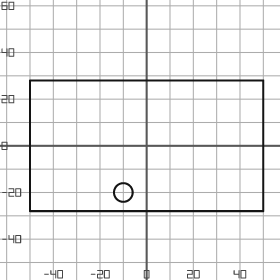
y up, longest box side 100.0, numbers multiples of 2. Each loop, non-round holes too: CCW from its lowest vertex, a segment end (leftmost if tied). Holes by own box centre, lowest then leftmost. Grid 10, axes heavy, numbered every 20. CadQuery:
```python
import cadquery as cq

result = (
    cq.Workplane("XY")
    .moveTo(-50.0, -28.0)
    .lineTo(50.0, -28.0)
    .lineTo(50.0, 28.0)
    .lineTo(-50.0, 28.0)
    .close()
    .moveTo(-10.0, -20.0)
    .circle(4.0)
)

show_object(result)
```